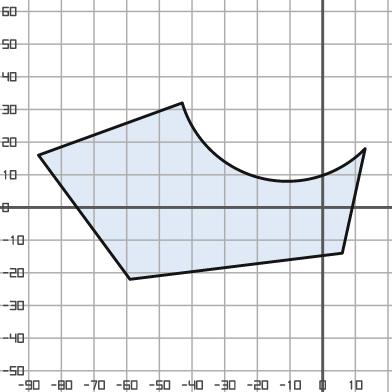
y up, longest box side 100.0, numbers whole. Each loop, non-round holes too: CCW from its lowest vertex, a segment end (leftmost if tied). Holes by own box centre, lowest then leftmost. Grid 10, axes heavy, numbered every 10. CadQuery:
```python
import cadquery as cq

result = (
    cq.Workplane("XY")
    .moveTo(-59.0, -22.0)
    .lineTo(6.0, -14.0)
    .lineTo(13.0, 18.0)
    .threePointArc((-19.0, 9.0), (-43.0, 32.0))
    .lineTo(-87.0, 16.0)
    .close()
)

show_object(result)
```